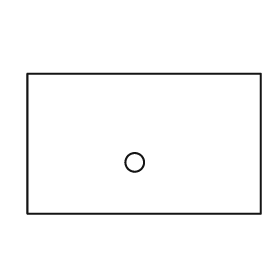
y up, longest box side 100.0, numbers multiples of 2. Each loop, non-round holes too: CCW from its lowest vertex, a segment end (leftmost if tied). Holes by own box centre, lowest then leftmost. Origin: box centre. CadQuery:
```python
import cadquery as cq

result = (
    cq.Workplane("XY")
    .moveTo(-50.0, -30.0)
    .lineTo(50.0, -30.0)
    .lineTo(50.0, 30.0)
    .lineTo(-50.0, 30.0)
    .close()
    .moveTo(-4.0, -8.0)
    .circle(4.0)
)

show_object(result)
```